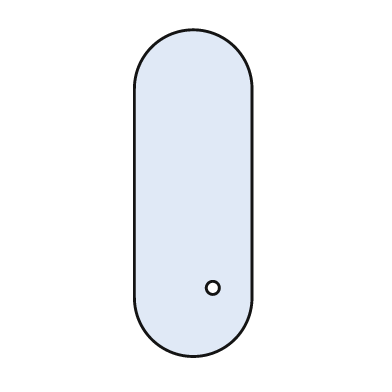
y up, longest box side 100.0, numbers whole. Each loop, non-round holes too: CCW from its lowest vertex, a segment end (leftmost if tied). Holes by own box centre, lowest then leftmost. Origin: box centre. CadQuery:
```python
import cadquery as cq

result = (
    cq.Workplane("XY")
    .moveTo(-18.0, -32.0)
    .threePointArc((0.0, -50.0), (18.0, -32.0))
    .lineTo(18.0, 32.0)
    .threePointArc((0.0, 50.0), (-18.0, 32.0))
    .close()
    .moveTo(6.0, -29.0)
    .circle(2.0)
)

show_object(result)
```